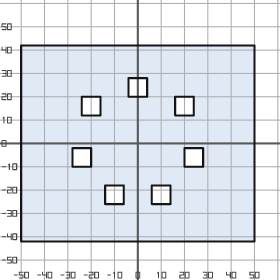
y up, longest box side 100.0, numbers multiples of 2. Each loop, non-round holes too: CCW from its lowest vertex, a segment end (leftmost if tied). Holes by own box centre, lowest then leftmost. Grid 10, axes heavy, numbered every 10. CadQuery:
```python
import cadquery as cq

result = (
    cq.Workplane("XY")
    .moveTo(-50.0, -42.0)
    .lineTo(50.0, -42.0)
    .lineTo(50.0, 42.0)
    .lineTo(-50.0, 42.0)
    .close()
    .moveTo(-14.0, -26.0)
    .lineTo(-6.0, -26.0)
    .lineTo(-6.0, -18.0)
    .lineTo(-14.0, -18.0)
    .close()
    .moveTo(6.0, -26.0)
    .lineTo(14.0, -26.0)
    .lineTo(14.0, -18.0)
    .lineTo(6.0, -18.0)
    .close()
    .moveTo(-28.0, -10.0)
    .lineTo(-20.0, -10.0)
    .lineTo(-20.0, -2.0)
    .lineTo(-28.0, -2.0)
    .close()
    .moveTo(20.0, -10.0)
    .lineTo(28.0, -10.0)
    .lineTo(28.0, -2.0)
    .lineTo(20.0, -2.0)
    .close()
    .moveTo(-24.0, 12.0)
    .lineTo(-16.0, 12.0)
    .lineTo(-16.0, 20.0)
    .lineTo(-24.0, 20.0)
    .close()
    .moveTo(16.0, 12.0)
    .lineTo(24.0, 12.0)
    .lineTo(24.0, 20.0)
    .lineTo(16.0, 20.0)
    .close()
    .moveTo(-4.0, 20.0)
    .lineTo(4.0, 20.0)
    .lineTo(4.0, 28.0)
    .lineTo(-4.0, 28.0)
    .close()
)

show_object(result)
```